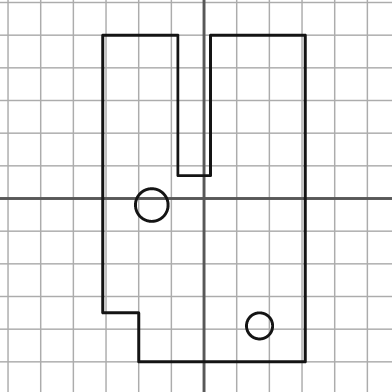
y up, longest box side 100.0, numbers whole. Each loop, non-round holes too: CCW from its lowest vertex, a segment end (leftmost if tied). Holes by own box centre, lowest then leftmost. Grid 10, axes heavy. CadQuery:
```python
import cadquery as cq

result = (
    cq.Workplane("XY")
    .moveTo(-20.0, -50.0)
    .lineTo(31.0, -50.0)
    .lineTo(31.0, 50.0)
    .lineTo(2.0, 50.0)
    .lineTo(2.0, 7.0)
    .lineTo(-8.0, 7.0)
    .lineTo(-8.0, 50.0)
    .lineTo(-31.0, 50.0)
    .lineTo(-31.0, -35.0)
    .lineTo(-20.0, -35.0)
    .close()
    .moveTo(17.0, -39.0)
    .circle(4.0)
    .moveTo(-16.0, -2.0)
    .circle(5.0)
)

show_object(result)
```